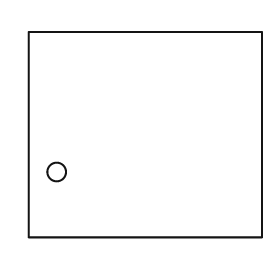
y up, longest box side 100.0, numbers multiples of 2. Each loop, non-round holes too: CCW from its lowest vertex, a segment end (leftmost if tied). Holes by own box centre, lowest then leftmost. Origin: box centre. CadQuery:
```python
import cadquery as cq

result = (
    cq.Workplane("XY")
    .moveTo(-50.0, -44.0)
    .lineTo(50.0, -44.0)
    .lineTo(50.0, 44.0)
    .lineTo(-50.0, 44.0)
    .close()
    .moveTo(-38.0, -16.0)
    .circle(4.0)
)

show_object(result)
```